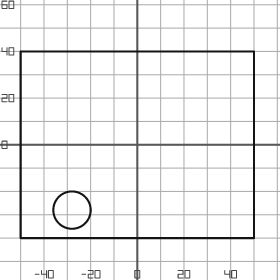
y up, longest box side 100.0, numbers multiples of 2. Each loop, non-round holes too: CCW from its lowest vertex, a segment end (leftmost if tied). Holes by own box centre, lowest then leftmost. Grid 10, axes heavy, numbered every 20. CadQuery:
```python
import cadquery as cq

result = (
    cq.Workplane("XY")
    .moveTo(-50.0, -40.0)
    .lineTo(50.0, -40.0)
    .lineTo(50.0, 40.0)
    .lineTo(-50.0, 40.0)
    .close()
    .moveTo(-28.0, -28.0)
    .circle(8.0)
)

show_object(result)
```